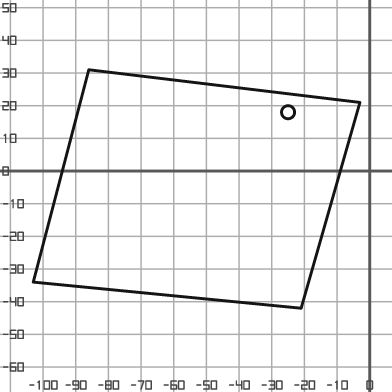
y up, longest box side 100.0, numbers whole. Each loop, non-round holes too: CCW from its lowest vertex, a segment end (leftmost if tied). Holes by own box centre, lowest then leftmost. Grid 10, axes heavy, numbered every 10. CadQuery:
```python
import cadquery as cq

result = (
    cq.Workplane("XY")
    .moveTo(-21.0, -42.0)
    .lineTo(-3.0, 21.0)
    .lineTo(-86.0, 31.0)
    .lineTo(-103.0, -34.0)
    .close()
    .moveTo(-25.0, 18.0)
    .circle(2.0)
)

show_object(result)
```